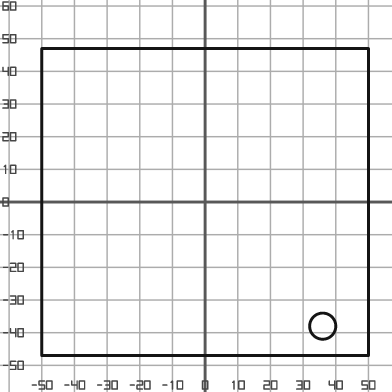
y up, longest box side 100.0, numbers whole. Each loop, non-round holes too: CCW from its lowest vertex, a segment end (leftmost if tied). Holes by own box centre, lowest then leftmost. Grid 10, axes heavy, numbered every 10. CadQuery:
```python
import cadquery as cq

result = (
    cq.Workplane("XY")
    .moveTo(-50.0, -47.0)
    .lineTo(50.0, -47.0)
    .lineTo(50.0, 47.0)
    .lineTo(-50.0, 47.0)
    .close()
    .moveTo(36.0, -38.0)
    .circle(4.0)
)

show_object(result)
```